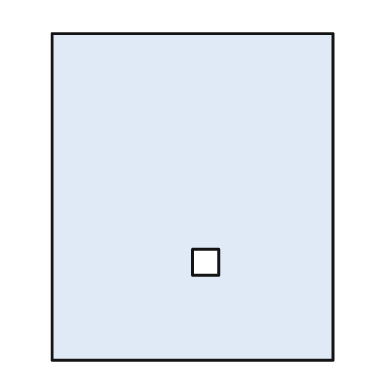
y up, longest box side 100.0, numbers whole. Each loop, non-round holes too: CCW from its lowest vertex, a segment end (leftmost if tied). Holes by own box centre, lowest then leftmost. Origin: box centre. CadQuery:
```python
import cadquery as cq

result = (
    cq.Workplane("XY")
    .moveTo(-43.0, -50.0)
    .lineTo(43.0, -50.0)
    .lineTo(43.0, 50.0)
    .lineTo(-43.0, 50.0)
    .close()
    .moveTo(0.0, -24.0)
    .lineTo(8.0, -24.0)
    .lineTo(8.0, -16.0)
    .lineTo(0.0, -16.0)
    .close()
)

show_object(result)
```